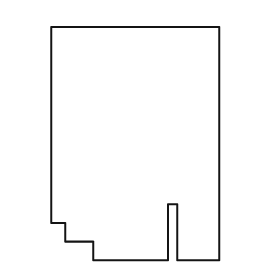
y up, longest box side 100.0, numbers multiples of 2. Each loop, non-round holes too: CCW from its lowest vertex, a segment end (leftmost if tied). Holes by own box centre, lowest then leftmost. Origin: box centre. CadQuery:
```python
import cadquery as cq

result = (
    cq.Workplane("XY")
    .moveTo(-18.0, -50.0)
    .lineTo(14.0, -50.0)
    .lineTo(14.0, -26.0)
    .lineTo(18.0, -26.0)
    .lineTo(18.0, -50.0)
    .lineTo(36.0, -50.0)
    .lineTo(36.0, 50.0)
    .lineTo(-36.0, 50.0)
    .lineTo(-36.0, -34.0)
    .lineTo(-30.0, -34.0)
    .lineTo(-30.0, -42.0)
    .lineTo(-18.0, -42.0)
    .close()
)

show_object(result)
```